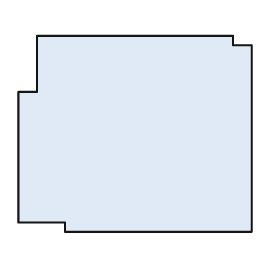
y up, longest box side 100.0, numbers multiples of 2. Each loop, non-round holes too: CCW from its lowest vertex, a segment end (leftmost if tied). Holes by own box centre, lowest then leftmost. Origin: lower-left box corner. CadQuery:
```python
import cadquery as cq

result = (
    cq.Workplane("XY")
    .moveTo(20.0, 0.0)
    .lineTo(100.0, 0.0)
    .lineTo(100.0, 80.0)
    .lineTo(92.0, 80.0)
    .lineTo(92.0, 84.0)
    .lineTo(8.0, 84.0)
    .lineTo(8.0, 60.0)
    .lineTo(0.0, 60.0)
    .lineTo(0.0, 4.0)
    .lineTo(20.0, 4.0)
    .close()
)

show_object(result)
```